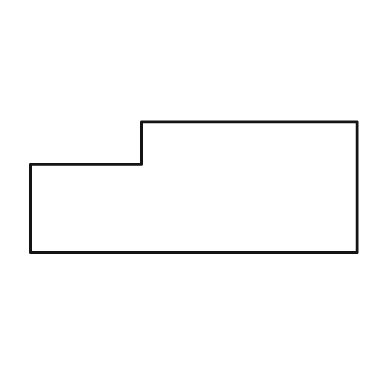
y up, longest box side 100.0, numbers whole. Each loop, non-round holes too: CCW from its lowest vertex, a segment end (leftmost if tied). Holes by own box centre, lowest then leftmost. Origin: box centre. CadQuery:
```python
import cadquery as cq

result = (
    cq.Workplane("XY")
    .moveTo(-50.0, -20.0)
    .lineTo(50.0, -20.0)
    .lineTo(50.0, 20.0)
    .lineTo(-16.0, 20.0)
    .lineTo(-16.0, 7.0)
    .lineTo(-50.0, 7.0)
    .close()
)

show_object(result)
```